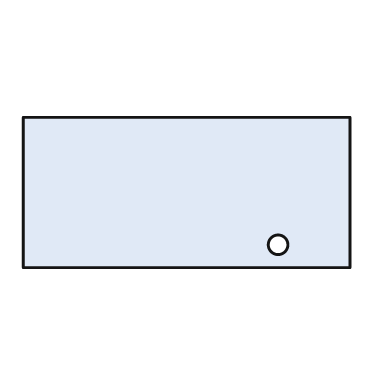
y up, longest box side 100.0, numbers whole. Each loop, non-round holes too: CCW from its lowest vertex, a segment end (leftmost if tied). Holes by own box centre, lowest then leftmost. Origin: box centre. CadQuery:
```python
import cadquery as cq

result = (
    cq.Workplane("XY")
    .moveTo(-50.0, -23.0)
    .lineTo(50.0, -23.0)
    .lineTo(50.0, 23.0)
    .lineTo(-50.0, 23.0)
    .close()
    .moveTo(28.0, -16.0)
    .circle(3.0)
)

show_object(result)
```